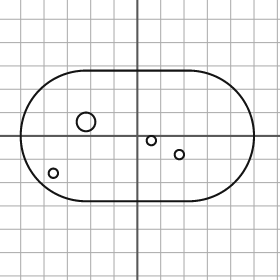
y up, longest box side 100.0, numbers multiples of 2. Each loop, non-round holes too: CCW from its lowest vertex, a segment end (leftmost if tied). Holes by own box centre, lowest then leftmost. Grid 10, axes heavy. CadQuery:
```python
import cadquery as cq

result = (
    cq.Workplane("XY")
    .moveTo(-22.0, -28.0)
    .lineTo(22.0, -28.0)
    .threePointArc((50.0, 0.0), (22.0, 28.0))
    .lineTo(-22.0, 28.0)
    .threePointArc((-50.0, 0.0), (-22.0, -28.0))
    .close()
    .moveTo(-36.0, -16.0)
    .circle(2.0)
    .moveTo(18.0, -8.0)
    .circle(2.0)
    .moveTo(6.0, -2.0)
    .circle(2.0)
    .moveTo(-22.0, 6.0)
    .circle(4.0)
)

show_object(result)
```